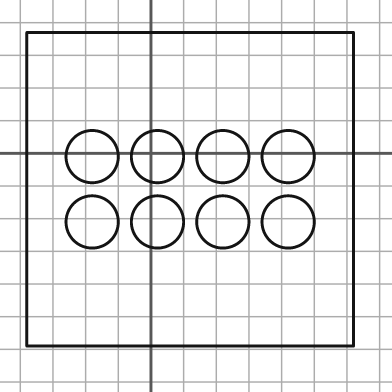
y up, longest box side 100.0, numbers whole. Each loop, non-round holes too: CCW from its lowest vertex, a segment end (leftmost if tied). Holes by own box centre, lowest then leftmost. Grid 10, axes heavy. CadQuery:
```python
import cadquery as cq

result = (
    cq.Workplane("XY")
    .moveTo(-38.0, -59.0)
    .lineTo(62.0, -59.0)
    .lineTo(62.0, 37.0)
    .lineTo(-38.0, 37.0)
    .close()
    .moveTo(-18.0, -21.0)
    .circle(8.0)
    .moveTo(2.0, -21.0)
    .circle(8.0)
    .moveTo(22.0, -21.0)
    .circle(8.0)
    .moveTo(42.0, -21.0)
    .circle(8.0)
    .moveTo(-18.0, -1.0)
    .circle(8.0)
    .moveTo(2.0, -1.0)
    .circle(8.0)
    .moveTo(22.0, -1.0)
    .circle(8.0)
    .moveTo(42.0, -1.0)
    .circle(8.0)
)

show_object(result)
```